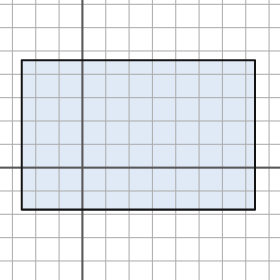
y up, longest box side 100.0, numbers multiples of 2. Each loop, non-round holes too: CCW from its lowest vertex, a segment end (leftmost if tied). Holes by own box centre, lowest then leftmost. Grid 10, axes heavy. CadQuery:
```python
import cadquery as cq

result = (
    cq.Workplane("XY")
    .moveTo(-26.0, -18.0)
    .lineTo(74.0, -18.0)
    .lineTo(74.0, 46.0)
    .lineTo(-26.0, 46.0)
    .close()
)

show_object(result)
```